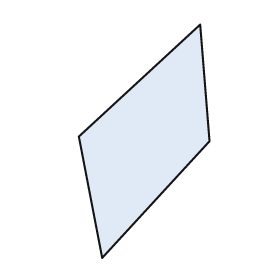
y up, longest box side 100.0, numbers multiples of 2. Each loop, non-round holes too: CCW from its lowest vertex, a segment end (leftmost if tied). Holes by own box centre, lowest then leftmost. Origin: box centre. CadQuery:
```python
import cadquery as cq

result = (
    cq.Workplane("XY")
    .moveTo(-18.0, -50.0)
    .lineTo(28.0, 0.0)
    .lineTo(24.0, 50.0)
    .lineTo(-28.0, 2.0)
    .close()
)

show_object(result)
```